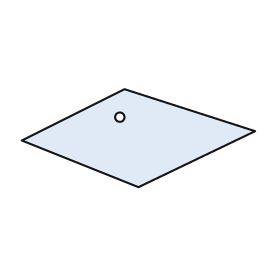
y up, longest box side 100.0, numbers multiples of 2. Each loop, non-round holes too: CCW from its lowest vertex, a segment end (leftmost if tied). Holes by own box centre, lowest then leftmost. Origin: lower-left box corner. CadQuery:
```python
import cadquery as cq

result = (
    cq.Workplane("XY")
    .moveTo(50.0, 0.0)
    .lineTo(100.0, 24.0)
    .lineTo(44.0, 42.0)
    .lineTo(0.0, 20.0)
    .close()
    .moveTo(42.0, 30.0)
    .circle(2.0)
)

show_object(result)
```